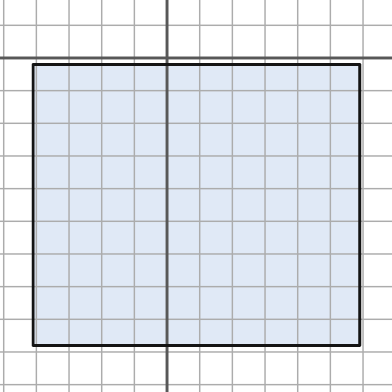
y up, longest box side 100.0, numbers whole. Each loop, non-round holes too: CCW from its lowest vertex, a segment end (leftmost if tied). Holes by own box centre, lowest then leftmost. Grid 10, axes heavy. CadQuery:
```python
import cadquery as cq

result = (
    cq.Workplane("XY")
    .moveTo(-41.0, -88.0)
    .lineTo(59.0, -88.0)
    .lineTo(59.0, -2.0)
    .lineTo(-41.0, -2.0)
    .close()
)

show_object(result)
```